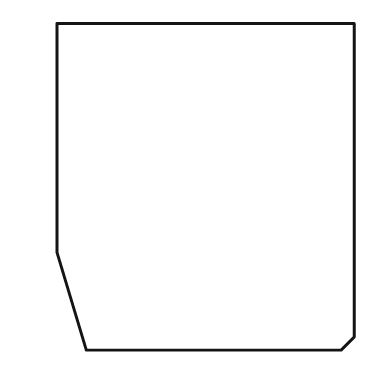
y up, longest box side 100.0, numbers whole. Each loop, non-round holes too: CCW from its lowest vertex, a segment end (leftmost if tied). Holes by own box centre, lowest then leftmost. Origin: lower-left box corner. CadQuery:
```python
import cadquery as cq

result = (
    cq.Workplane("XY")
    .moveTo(9.0, 0.0)
    .lineTo(87.0, 0.0)
    .lineTo(91.0, 4.0)
    .lineTo(91.0, 100.0)
    .lineTo(0.0, 100.0)
    .lineTo(0.0, 30.0)
    .close()
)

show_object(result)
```